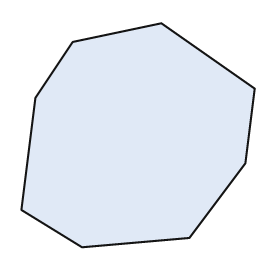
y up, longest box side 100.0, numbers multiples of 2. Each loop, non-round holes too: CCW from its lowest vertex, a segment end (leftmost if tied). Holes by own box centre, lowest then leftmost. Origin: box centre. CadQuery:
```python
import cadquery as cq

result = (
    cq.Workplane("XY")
    .moveTo(-24.0, -48.0)
    .lineTo(22.0, -44.0)
    .lineTo(46.0, -12.0)
    .lineTo(50.0, 20.0)
    .lineTo(10.0, 48.0)
    .lineTo(-28.0, 40.0)
    .lineTo(-44.0, 16.0)
    .lineTo(-50.0, -32.0)
    .close()
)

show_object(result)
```